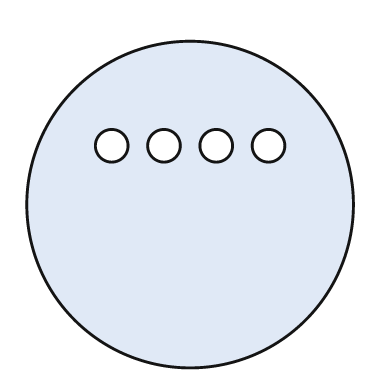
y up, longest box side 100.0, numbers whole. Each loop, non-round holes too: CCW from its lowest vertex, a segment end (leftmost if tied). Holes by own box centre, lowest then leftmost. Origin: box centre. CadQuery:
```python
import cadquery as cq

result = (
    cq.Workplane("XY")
    .moveTo(0.0, 0.0)
    .circle(50.0)
    .moveTo(-24.0, 18.0)
    .circle(5.0)
    .moveTo(-8.0, 18.0)
    .circle(5.0)
    .moveTo(8.0, 18.0)
    .circle(5.0)
    .moveTo(24.0, 18.0)
    .circle(5.0)
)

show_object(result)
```